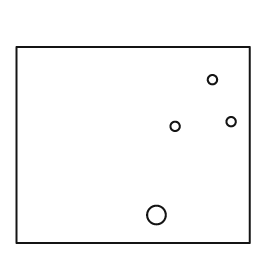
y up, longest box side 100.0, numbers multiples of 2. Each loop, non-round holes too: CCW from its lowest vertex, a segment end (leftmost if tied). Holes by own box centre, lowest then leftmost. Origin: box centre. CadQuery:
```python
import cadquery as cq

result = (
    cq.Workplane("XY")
    .moveTo(-50.0, -42.0)
    .lineTo(50.0, -42.0)
    .lineTo(50.0, 42.0)
    .lineTo(-50.0, 42.0)
    .close()
    .moveTo(10.0, -30.0)
    .circle(4.0)
    .moveTo(18.0, 8.0)
    .circle(2.0)
    .moveTo(42.0, 10.0)
    .circle(2.0)
    .moveTo(34.0, 28.0)
    .circle(2.0)
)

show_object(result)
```